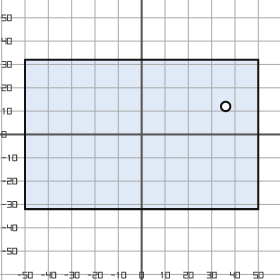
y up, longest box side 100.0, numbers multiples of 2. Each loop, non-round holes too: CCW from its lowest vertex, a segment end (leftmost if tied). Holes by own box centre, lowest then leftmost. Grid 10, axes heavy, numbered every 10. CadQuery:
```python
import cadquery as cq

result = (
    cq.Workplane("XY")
    .moveTo(-50.0, -32.0)
    .lineTo(50.0, -32.0)
    .lineTo(50.0, 32.0)
    .lineTo(-50.0, 32.0)
    .close()
    .moveTo(36.0, 12.0)
    .circle(2.0)
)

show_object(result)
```